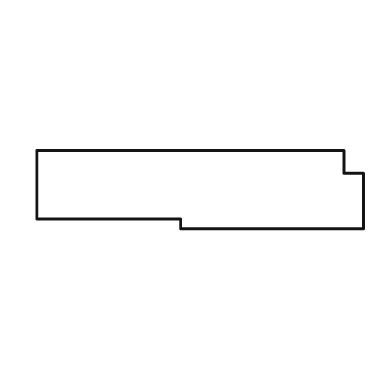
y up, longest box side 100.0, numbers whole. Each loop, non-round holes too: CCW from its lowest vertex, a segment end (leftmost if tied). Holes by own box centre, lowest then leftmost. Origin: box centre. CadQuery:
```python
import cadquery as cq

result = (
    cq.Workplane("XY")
    .moveTo(-6.0, -12.0)
    .lineTo(50.0, -12.0)
    .lineTo(50.0, 5.0)
    .lineTo(44.0, 5.0)
    .lineTo(44.0, 12.0)
    .lineTo(-50.0, 12.0)
    .lineTo(-50.0, -9.0)
    .lineTo(-6.0, -9.0)
    .close()
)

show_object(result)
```